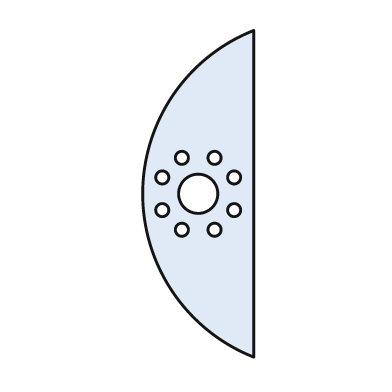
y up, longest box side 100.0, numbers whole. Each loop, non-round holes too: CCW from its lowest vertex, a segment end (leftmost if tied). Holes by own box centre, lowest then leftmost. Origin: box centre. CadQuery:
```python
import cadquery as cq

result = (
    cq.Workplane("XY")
    .moveTo(17.0, -50.0)
    .lineTo(17.0, 50.0)
    .threePointArc((-17.0, 0.0), (17.0, -50.0))
    .close()
    .moveTo(-5.0, -11.0)
    .circle(2.0)
    .moveTo(5.0, -11.0)
    .circle(2.0)
    .moveTo(-11.0, -5.0)
    .circle(2.0)
    .moveTo(11.0, -5.0)
    .circle(2.0)
    .moveTo(0.0, 0.0)
    .circle(6.0)
    .moveTo(-11.0, 5.0)
    .circle(2.0)
    .moveTo(11.0, 5.0)
    .circle(2.0)
    .moveTo(-5.0, 11.0)
    .circle(2.0)
    .moveTo(5.0, 11.0)
    .circle(2.0)
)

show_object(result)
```